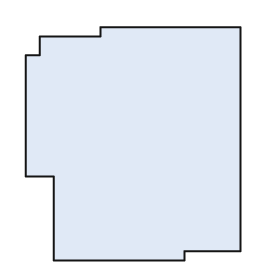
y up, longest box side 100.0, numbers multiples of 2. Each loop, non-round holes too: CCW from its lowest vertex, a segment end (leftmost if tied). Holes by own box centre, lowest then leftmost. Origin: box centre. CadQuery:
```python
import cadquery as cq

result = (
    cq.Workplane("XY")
    .moveTo(-34.0, -50.0)
    .lineTo(22.0, -50.0)
    .lineTo(22.0, -46.0)
    .lineTo(46.0, -46.0)
    .lineTo(46.0, 50.0)
    .lineTo(-14.0, 50.0)
    .lineTo(-14.0, 46.0)
    .lineTo(-40.0, 46.0)
    .lineTo(-40.0, 38.0)
    .lineTo(-46.0, 38.0)
    .lineTo(-46.0, -14.0)
    .lineTo(-34.0, -14.0)
    .close()
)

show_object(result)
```